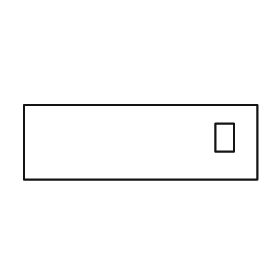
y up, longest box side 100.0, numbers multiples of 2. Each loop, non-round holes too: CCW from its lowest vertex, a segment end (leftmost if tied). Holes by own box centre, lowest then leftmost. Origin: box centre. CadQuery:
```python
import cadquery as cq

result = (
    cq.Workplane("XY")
    .moveTo(-50.0, -16.0)
    .lineTo(50.0, -16.0)
    .lineTo(50.0, 16.0)
    .lineTo(-50.0, 16.0)
    .close()
    .moveTo(32.0, -4.0)
    .lineTo(40.0, -4.0)
    .lineTo(40.0, 8.0)
    .lineTo(32.0, 8.0)
    .close()
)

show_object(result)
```